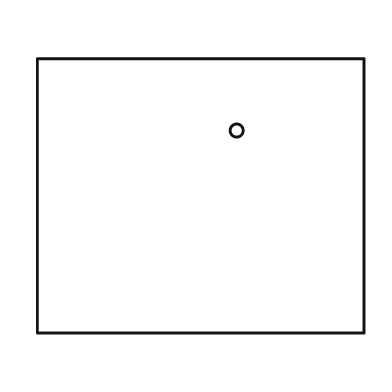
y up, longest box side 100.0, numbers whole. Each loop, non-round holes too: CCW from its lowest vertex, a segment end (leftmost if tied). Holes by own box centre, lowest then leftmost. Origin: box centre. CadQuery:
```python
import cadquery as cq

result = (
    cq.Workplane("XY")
    .moveTo(-50.0, -42.0)
    .lineTo(50.0, -42.0)
    .lineTo(50.0, 42.0)
    .lineTo(-50.0, 42.0)
    .close()
    .moveTo(11.0, 20.0)
    .circle(2.0)
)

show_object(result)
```